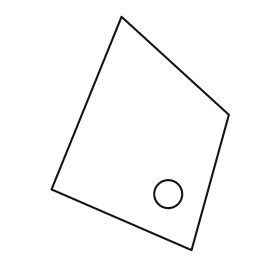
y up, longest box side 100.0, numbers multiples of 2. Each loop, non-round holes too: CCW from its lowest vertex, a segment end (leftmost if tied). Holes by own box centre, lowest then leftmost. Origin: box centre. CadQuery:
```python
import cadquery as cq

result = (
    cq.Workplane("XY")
    .moveTo(22.0, -50.0)
    .lineTo(38.0, 8.0)
    .lineTo(-8.0, 50.0)
    .lineTo(-38.0, -24.0)
    .close()
    .moveTo(12.0, -26.0)
    .circle(6.0)
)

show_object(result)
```